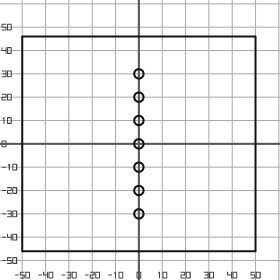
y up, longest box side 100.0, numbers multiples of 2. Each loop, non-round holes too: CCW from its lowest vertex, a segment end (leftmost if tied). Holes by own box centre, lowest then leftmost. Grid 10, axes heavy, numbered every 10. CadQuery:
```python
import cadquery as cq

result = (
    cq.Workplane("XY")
    .moveTo(-50.0, -46.0)
    .lineTo(50.0, -46.0)
    .lineTo(50.0, 46.0)
    .lineTo(-50.0, 46.0)
    .close()
    .moveTo(0.0, -30.0)
    .circle(2.0)
    .moveTo(0.0, -20.0)
    .circle(2.0)
    .moveTo(0.0, -10.0)
    .circle(2.0)
    .moveTo(0.0, 0.0)
    .circle(2.0)
    .moveTo(0.0, 10.0)
    .circle(2.0)
    .moveTo(0.0, 20.0)
    .circle(2.0)
    .moveTo(0.0, 30.0)
    .circle(2.0)
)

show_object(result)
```